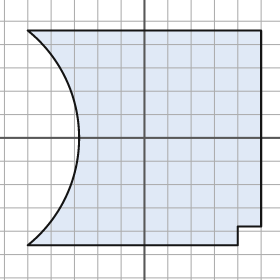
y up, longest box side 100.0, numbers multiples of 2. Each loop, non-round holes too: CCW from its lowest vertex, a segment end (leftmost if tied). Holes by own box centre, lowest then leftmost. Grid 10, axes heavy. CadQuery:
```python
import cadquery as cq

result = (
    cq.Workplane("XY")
    .moveTo(-50.0, -46.0)
    .lineTo(40.0, -46.0)
    .lineTo(40.0, -38.0)
    .lineTo(50.0, -38.0)
    .lineTo(50.0, 46.0)
    .lineTo(-50.0, 46.0)
    .threePointArc((-28.0, 0.0), (-50.0, -46.0))
    .close()
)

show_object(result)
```